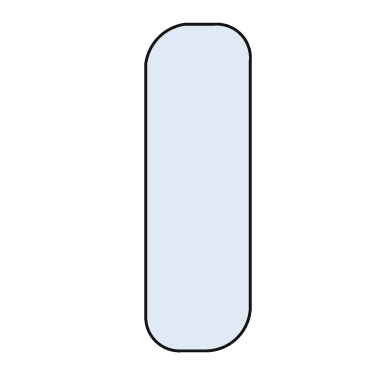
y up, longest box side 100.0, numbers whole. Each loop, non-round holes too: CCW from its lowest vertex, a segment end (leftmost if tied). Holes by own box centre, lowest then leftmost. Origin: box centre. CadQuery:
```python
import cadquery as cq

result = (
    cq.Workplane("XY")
    .moveTo(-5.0, -50.0)
    .lineTo(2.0, -50.0)
    .threePointArc((12.0, -46.0), (16.0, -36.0))
    .lineTo(16.0, 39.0)
    .threePointArc((13.0, 47.0), (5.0, 50.0))
    .lineTo(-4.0, 50.0)
    .threePointArc((-12.0, 46.0), (-16.0, 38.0))
    .lineTo(-16.0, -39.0)
    .threePointArc((-13.0, -47.0), (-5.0, -50.0))
    .close()
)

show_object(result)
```